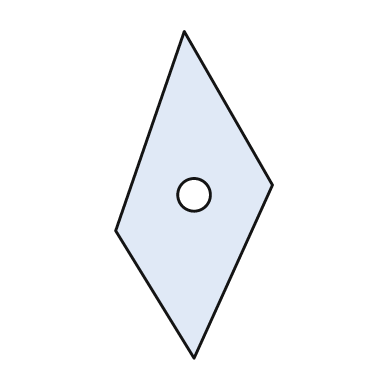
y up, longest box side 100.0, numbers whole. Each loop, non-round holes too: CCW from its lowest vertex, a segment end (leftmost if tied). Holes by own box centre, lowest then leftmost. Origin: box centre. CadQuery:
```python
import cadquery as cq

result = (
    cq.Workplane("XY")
    .moveTo(0.0, -50.0)
    .lineTo(24.0, 3.0)
    .lineTo(-3.0, 50.0)
    .lineTo(-24.0, -11.0)
    .close()
    .moveTo(0.0, 0.0)
    .circle(5.0)
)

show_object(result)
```